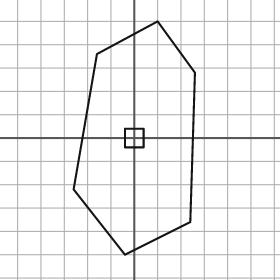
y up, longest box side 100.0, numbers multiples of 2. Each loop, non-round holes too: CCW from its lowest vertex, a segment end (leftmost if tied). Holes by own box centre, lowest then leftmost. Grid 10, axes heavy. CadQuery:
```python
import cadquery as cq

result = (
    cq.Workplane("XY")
    .moveTo(-4.0, -50.0)
    .lineTo(24.0, -36.0)
    .lineTo(26.0, 28.0)
    .lineTo(10.0, 50.0)
    .lineTo(-16.0, 36.0)
    .lineTo(-26.0, -22.0)
    .close()
    .moveTo(-4.0, -4.0)
    .lineTo(4.0, -4.0)
    .lineTo(4.0, 4.0)
    .lineTo(-4.0, 4.0)
    .close()
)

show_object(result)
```